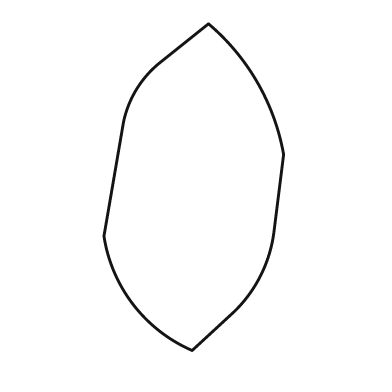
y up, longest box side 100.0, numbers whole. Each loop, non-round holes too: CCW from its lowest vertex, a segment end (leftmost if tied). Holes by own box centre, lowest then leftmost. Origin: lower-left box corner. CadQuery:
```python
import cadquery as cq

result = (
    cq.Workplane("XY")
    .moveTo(27.0, 0.0)
    .lineTo(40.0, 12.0)
    .threePointArc((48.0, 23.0), (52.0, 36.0))
    .lineTo(55.0, 60.0)
    .threePointArc((47.0, 82.0), (32.0, 100.0))
    .lineTo(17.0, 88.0)
    .threePointArc((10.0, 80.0), (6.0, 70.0))
    .lineTo(0.0, 35.0)
    .threePointArc((9.0, 14.0), (27.0, 0.0))
    .close()
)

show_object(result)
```